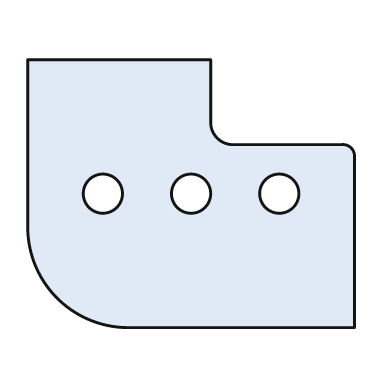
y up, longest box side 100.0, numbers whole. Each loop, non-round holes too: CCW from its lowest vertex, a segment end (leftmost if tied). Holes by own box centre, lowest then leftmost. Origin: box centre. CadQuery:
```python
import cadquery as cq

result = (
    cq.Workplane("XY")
    .moveTo(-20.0, -41.0)
    .lineTo(50.0, -41.0)
    .lineTo(50.0, 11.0)
    .threePointArc((49.0, 14.0), (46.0, 15.0))
    .lineTo(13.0, 15.0)
    .threePointArc((8.0, 17.0), (6.0, 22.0))
    .lineTo(6.0, 41.0)
    .lineTo(-50.0, 41.0)
    .lineTo(-50.0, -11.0)
    .threePointArc((-41.0, -32.0), (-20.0, -41.0))
    .close()
    .moveTo(-27.0, 0.0)
    .circle(6.0)
    .moveTo(0.0, 0.0)
    .circle(6.0)
    .moveTo(27.0, 0.0)
    .circle(6.0)
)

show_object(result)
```